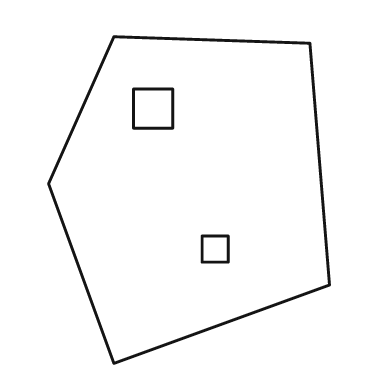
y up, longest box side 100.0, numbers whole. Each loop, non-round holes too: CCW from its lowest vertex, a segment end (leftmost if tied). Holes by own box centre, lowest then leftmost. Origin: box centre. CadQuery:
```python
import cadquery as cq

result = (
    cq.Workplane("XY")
    .moveTo(-23.0, -50.0)
    .lineTo(43.0, -26.0)
    .lineTo(37.0, 48.0)
    .lineTo(-23.0, 50.0)
    .lineTo(-43.0, 5.0)
    .close()
    .moveTo(4.0, -19.0)
    .lineTo(12.0, -19.0)
    .lineTo(12.0, -11.0)
    .lineTo(4.0, -11.0)
    .close()
    .moveTo(-17.0, 22.0)
    .lineTo(-5.0, 22.0)
    .lineTo(-5.0, 34.0)
    .lineTo(-17.0, 34.0)
    .close()
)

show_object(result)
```